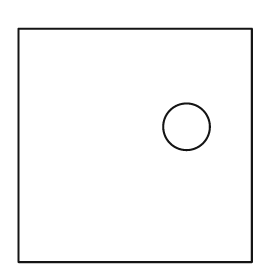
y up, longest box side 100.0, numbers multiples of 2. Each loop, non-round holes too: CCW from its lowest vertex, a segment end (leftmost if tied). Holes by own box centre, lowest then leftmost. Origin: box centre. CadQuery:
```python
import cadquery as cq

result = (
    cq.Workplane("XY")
    .moveTo(-50.0, -50.0)
    .lineTo(50.0, -50.0)
    .lineTo(50.0, 50.0)
    .lineTo(-50.0, 50.0)
    .close()
    .moveTo(22.0, 8.0)
    .circle(10.0)
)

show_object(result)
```